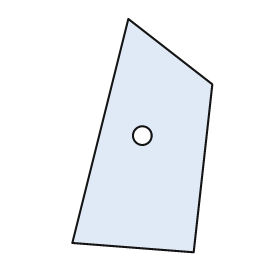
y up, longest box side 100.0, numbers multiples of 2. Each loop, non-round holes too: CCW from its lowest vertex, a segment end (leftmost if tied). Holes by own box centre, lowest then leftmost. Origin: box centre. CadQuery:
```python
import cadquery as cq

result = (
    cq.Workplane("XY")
    .moveTo(22.0, -50.0)
    .lineTo(30.0, 22.0)
    .lineTo(-6.0, 50.0)
    .lineTo(-30.0, -46.0)
    .close()
    .moveTo(0.0, 0.0)
    .circle(4.0)
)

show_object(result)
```